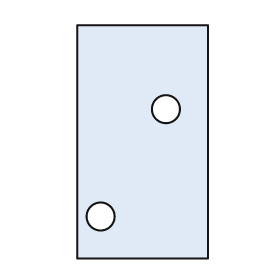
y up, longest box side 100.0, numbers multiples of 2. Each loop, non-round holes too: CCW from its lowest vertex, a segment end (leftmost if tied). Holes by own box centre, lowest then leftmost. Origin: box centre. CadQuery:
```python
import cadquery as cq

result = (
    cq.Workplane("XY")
    .moveTo(-28.0, -50.0)
    .lineTo(28.0, -50.0)
    .lineTo(28.0, 50.0)
    .lineTo(-28.0, 50.0)
    .close()
    .moveTo(-18.0, -32.0)
    .circle(6.0)
    .moveTo(10.0, 14.0)
    .circle(6.0)
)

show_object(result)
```